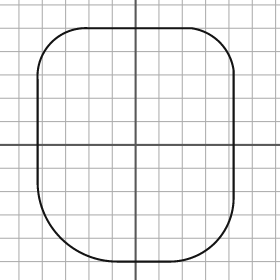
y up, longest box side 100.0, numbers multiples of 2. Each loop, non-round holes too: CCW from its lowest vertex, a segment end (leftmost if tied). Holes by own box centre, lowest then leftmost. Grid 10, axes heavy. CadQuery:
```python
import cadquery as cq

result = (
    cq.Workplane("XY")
    .moveTo(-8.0, -50.0)
    .lineTo(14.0, -50.0)
    .threePointArc((34.0, -42.0), (42.0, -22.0))
    .lineTo(42.0, 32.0)
    .threePointArc((36.0, 44.0), (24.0, 50.0))
    .lineTo(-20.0, 50.0)
    .threePointArc((-36.0, 44.0), (-42.0, 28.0))
    .lineTo(-42.0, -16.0)
    .threePointArc((-32.0, -40.0), (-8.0, -50.0))
    .close()
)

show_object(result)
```